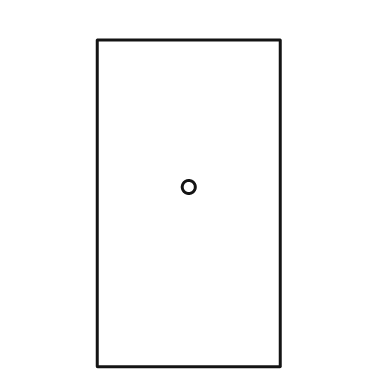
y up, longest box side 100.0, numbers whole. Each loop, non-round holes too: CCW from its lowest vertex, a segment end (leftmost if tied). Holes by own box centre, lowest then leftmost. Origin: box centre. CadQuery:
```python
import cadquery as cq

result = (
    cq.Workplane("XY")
    .moveTo(-28.0, -50.0)
    .lineTo(28.0, -50.0)
    .lineTo(28.0, 50.0)
    .lineTo(-28.0, 50.0)
    .close()
    .moveTo(0.0, 5.0)
    .circle(2.0)
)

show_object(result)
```